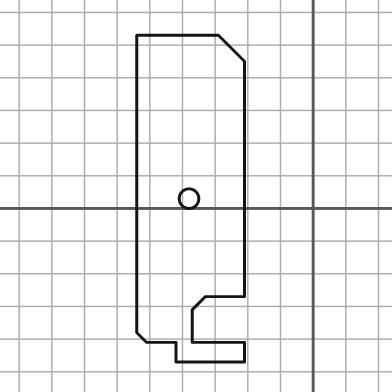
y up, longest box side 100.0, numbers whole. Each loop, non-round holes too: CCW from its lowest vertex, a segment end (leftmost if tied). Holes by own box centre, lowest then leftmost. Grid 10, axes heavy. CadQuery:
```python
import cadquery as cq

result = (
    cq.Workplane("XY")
    .moveTo(-42.0, -47.0)
    .lineTo(-21.0, -47.0)
    .lineTo(-21.0, -41.0)
    .lineTo(-37.0, -41.0)
    .lineTo(-37.0, -31.0)
    .lineTo(-33.0, -27.0)
    .lineTo(-21.0, -27.0)
    .lineTo(-21.0, 45.0)
    .lineTo(-29.0, 53.0)
    .lineTo(-54.0, 53.0)
    .lineTo(-54.0, -38.0)
    .lineTo(-51.0, -41.0)
    .lineTo(-42.0, -41.0)
    .close()
    .moveTo(-38.0, 3.0)
    .circle(3.0)
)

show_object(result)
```